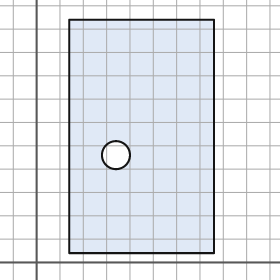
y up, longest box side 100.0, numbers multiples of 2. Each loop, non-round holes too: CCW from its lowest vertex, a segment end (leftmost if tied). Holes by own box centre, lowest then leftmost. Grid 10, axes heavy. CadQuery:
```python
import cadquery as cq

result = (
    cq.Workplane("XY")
    .moveTo(14.0, 4.0)
    .lineTo(76.0, 4.0)
    .lineTo(76.0, 104.0)
    .lineTo(14.0, 104.0)
    .close()
    .moveTo(34.0, 46.0)
    .circle(6.0)
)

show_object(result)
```